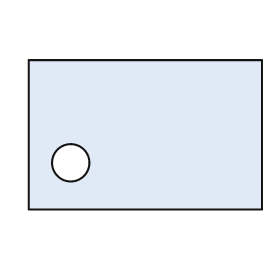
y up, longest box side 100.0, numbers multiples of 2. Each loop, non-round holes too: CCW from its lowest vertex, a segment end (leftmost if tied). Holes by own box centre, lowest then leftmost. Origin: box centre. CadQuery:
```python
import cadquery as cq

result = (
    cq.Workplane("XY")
    .moveTo(-50.0, -32.0)
    .lineTo(50.0, -32.0)
    .lineTo(50.0, 32.0)
    .lineTo(-50.0, 32.0)
    .close()
    .moveTo(-32.0, -12.0)
    .circle(8.0)
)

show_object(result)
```